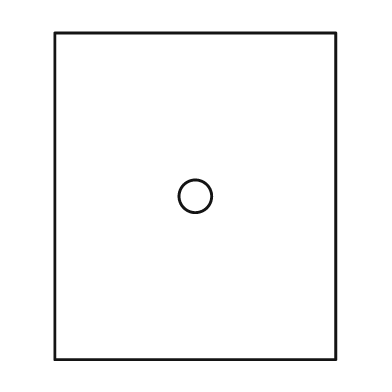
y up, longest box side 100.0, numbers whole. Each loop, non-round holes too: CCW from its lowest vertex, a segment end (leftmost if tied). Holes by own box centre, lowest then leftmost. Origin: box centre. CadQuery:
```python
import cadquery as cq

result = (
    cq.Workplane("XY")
    .moveTo(-43.0, -50.0)
    .lineTo(43.0, -50.0)
    .lineTo(43.0, 50.0)
    .lineTo(-43.0, 50.0)
    .close()
    .moveTo(0.0, 0.0)
    .circle(5.0)
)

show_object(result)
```